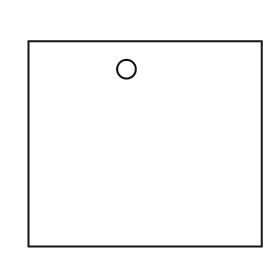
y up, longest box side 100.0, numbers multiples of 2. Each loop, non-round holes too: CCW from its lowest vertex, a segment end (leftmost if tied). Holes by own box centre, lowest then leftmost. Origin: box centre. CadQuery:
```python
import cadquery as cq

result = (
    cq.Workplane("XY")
    .moveTo(-50.0, -44.0)
    .lineTo(50.0, -44.0)
    .lineTo(50.0, 44.0)
    .lineTo(-50.0, 44.0)
    .close()
    .moveTo(-8.0, 32.0)
    .circle(4.0)
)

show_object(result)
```